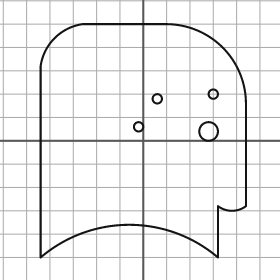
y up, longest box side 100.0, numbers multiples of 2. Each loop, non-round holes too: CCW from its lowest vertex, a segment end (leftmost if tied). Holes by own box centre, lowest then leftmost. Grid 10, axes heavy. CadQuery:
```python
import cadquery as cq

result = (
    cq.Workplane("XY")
    .moveTo(-44.0, -50.0)
    .threePointArc((-6.0, -36.0), (32.0, -50.0))
    .lineTo(32.0, -28.0)
    .threePointArc((38.0, -30.0), (44.0, -28.0))
    .lineTo(44.0, 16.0)
    .threePointArc((34.0, 40.0), (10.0, 50.0))
    .lineTo(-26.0, 50.0)
    .threePointArc((-38.0, 44.0), (-44.0, 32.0))
    .close()
    .moveTo(28.0, 4.0)
    .circle(4.0)
    .moveTo(-2.0, 6.0)
    .circle(2.0)
    .moveTo(6.0, 18.0)
    .circle(2.0)
    .moveTo(30.0, 20.0)
    .circle(2.0)
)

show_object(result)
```